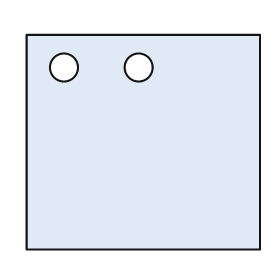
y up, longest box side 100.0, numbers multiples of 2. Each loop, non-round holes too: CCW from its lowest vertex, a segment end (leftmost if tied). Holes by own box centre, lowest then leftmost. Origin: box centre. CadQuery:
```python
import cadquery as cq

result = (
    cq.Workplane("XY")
    .moveTo(-50.0, -46.0)
    .lineTo(50.0, -46.0)
    .lineTo(50.0, 46.0)
    .lineTo(-50.0, 46.0)
    .close()
    .moveTo(-34.0, 32.0)
    .circle(6.0)
    .moveTo(-2.0, 32.0)
    .circle(6.0)
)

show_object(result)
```